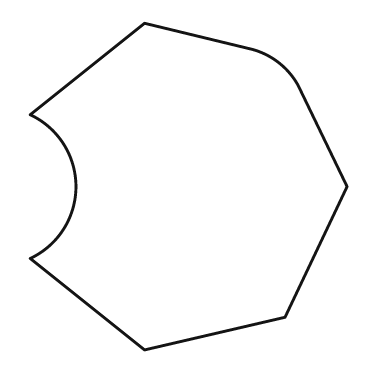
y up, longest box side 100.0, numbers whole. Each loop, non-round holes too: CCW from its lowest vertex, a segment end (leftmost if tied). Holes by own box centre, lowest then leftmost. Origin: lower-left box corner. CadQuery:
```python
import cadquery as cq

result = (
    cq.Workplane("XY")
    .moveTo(35.0, 0.0)
    .lineTo(78.0, 10.0)
    .lineTo(97.0, 50.0)
    .lineTo(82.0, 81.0)
    .threePointArc((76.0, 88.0), (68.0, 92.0))
    .lineTo(35.0, 100.0)
    .lineTo(0.0, 72.0)
    .threePointArc((14.0, 50.0), (0.0, 28.0))
    .close()
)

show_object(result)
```